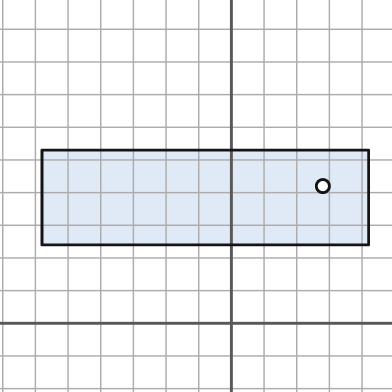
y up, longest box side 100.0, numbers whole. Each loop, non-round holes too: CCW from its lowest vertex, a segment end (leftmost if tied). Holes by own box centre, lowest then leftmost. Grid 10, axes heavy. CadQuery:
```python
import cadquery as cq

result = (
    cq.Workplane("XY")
    .moveTo(-58.0, 24.0)
    .lineTo(42.0, 24.0)
    .lineTo(42.0, 53.0)
    .lineTo(-58.0, 53.0)
    .close()
    .moveTo(28.0, 42.0)
    .circle(2.0)
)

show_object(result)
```